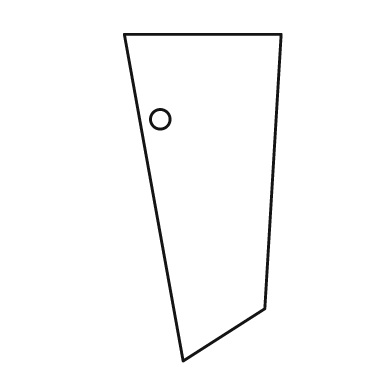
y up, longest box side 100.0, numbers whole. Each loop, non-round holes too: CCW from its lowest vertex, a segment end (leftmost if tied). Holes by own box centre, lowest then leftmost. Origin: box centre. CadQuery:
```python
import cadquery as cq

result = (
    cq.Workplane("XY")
    .moveTo(-6.0, -50.0)
    .lineTo(19.0, -34.0)
    .lineTo(24.0, 50.0)
    .lineTo(-24.0, 50.0)
    .close()
    .moveTo(-13.0, 24.0)
    .circle(3.0)
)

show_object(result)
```